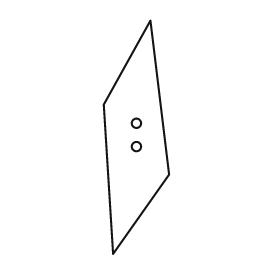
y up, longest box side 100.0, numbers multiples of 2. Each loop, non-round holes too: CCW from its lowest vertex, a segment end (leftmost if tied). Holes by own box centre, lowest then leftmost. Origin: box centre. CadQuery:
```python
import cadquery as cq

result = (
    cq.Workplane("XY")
    .moveTo(-10.0, -50.0)
    .lineTo(14.0, -16.0)
    .lineTo(6.0, 50.0)
    .lineTo(-14.0, 14.0)
    .close()
    .moveTo(0.0, -4.0)
    .circle(2.0)
    .moveTo(0.0, 6.0)
    .circle(2.0)
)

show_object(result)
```